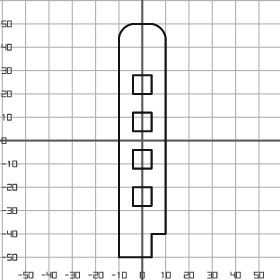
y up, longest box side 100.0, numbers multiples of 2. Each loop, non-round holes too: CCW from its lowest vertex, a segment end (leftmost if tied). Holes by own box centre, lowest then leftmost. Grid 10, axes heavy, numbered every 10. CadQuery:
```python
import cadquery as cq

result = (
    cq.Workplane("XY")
    .moveTo(-10.0, -50.0)
    .lineTo(4.0, -50.0)
    .lineTo(4.0, -40.0)
    .lineTo(10.0, -40.0)
    .lineTo(10.0, 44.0)
    .threePointArc((8.0, 48.0), (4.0, 50.0))
    .lineTo(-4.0, 50.0)
    .threePointArc((-8.0, 48.0), (-10.0, 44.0))
    .close()
    .moveTo(-4.0, -28.0)
    .lineTo(4.0, -28.0)
    .lineTo(4.0, -20.0)
    .lineTo(-4.0, -20.0)
    .close()
    .moveTo(-4.0, -12.0)
    .lineTo(4.0, -12.0)
    .lineTo(4.0, -4.0)
    .lineTo(-4.0, -4.0)
    .close()
    .moveTo(-4.0, 4.0)
    .lineTo(4.0, 4.0)
    .lineTo(4.0, 12.0)
    .lineTo(-4.0, 12.0)
    .close()
    .moveTo(-4.0, 20.0)
    .lineTo(4.0, 20.0)
    .lineTo(4.0, 28.0)
    .lineTo(-4.0, 28.0)
    .close()
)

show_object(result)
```